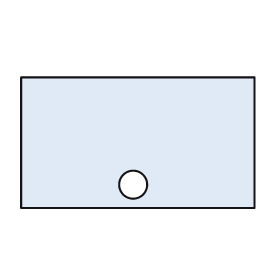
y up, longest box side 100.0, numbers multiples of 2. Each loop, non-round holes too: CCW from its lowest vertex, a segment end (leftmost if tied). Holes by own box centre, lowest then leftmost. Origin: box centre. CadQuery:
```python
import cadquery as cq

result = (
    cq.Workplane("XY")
    .moveTo(-50.0, -28.0)
    .lineTo(50.0, -28.0)
    .lineTo(50.0, 28.0)
    .lineTo(-50.0, 28.0)
    .close()
    .moveTo(-2.0, -18.0)
    .circle(6.0)
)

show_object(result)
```